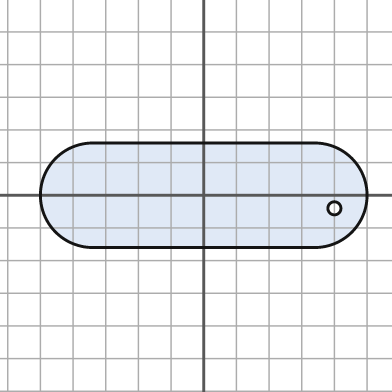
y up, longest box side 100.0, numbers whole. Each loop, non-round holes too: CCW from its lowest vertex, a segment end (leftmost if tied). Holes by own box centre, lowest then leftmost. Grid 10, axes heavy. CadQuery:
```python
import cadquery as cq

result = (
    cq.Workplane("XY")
    .moveTo(-34.0, -16.0)
    .lineTo(34.0, -16.0)
    .threePointArc((50.0, 0.0), (34.0, 16.0))
    .lineTo(-34.0, 16.0)
    .threePointArc((-50.0, 0.0), (-34.0, -16.0))
    .close()
    .moveTo(40.0, -4.0)
    .circle(2.0)
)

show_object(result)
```